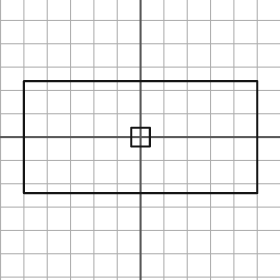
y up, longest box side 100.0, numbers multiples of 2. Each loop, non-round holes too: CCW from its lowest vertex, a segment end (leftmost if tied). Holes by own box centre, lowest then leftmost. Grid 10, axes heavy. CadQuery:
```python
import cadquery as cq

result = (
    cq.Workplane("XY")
    .moveTo(-50.0, -24.0)
    .lineTo(50.0, -24.0)
    .lineTo(50.0, 24.0)
    .lineTo(-50.0, 24.0)
    .close()
    .moveTo(-4.0, -4.0)
    .lineTo(4.0, -4.0)
    .lineTo(4.0, 4.0)
    .lineTo(-4.0, 4.0)
    .close()
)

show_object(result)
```